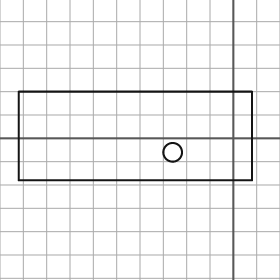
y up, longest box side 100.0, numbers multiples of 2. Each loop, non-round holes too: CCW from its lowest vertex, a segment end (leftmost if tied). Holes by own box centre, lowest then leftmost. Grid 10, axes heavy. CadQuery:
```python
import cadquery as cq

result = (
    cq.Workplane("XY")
    .moveTo(-92.0, -18.0)
    .lineTo(8.0, -18.0)
    .lineTo(8.0, 20.0)
    .lineTo(-92.0, 20.0)
    .close()
    .moveTo(-26.0, -6.0)
    .circle(4.0)
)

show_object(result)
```